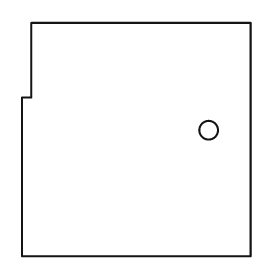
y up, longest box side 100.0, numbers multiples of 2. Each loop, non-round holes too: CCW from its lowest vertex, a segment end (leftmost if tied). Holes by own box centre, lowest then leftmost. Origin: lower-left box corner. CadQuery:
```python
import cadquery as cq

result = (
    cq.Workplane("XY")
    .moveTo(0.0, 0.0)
    .lineTo(98.0, 0.0)
    .lineTo(98.0, 100.0)
    .lineTo(4.0, 100.0)
    .lineTo(4.0, 68.0)
    .lineTo(0.0, 68.0)
    .close()
    .moveTo(80.0, 54.0)
    .circle(4.0)
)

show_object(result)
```